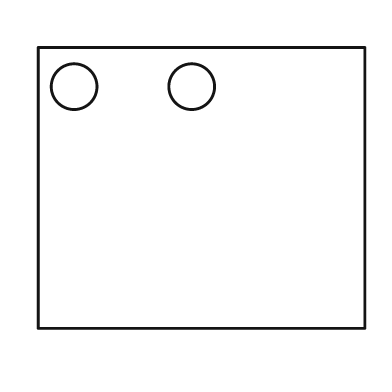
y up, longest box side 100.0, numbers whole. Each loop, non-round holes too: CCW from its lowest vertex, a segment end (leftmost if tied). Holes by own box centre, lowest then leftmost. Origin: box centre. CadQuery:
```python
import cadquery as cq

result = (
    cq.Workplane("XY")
    .moveTo(-50.0, -43.0)
    .lineTo(50.0, -43.0)
    .lineTo(50.0, 43.0)
    .lineTo(-50.0, 43.0)
    .close()
    .moveTo(-39.0, 31.0)
    .circle(7.0)
    .moveTo(-3.0, 31.0)
    .circle(7.0)
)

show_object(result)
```